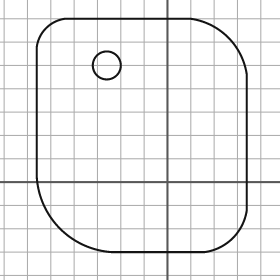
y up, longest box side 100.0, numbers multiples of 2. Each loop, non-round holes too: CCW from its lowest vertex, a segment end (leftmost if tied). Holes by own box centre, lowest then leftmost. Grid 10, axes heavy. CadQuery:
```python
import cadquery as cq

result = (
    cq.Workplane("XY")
    .moveTo(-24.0, -30.0)
    .lineTo(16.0, -30.0)
    .threePointArc((28.0, -24.0), (34.0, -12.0))
    .lineTo(34.0, 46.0)
    .threePointArc((26.0, 62.0), (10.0, 70.0))
    .lineTo(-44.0, 70.0)
    .threePointArc((-52.0, 66.0), (-56.0, 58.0))
    .lineTo(-56.0, 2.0)
    .threePointArc((-46.0, -20.0), (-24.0, -30.0))
    .close()
    .moveTo(-26.0, 50.0)
    .circle(6.0)
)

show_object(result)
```